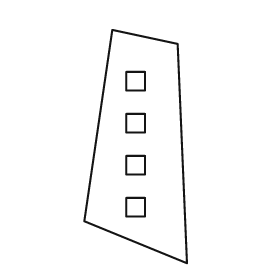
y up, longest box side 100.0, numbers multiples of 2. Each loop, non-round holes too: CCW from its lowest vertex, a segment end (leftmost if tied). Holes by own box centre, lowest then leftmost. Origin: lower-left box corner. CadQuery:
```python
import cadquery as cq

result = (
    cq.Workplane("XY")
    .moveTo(44.0, 0.0)
    .lineTo(40.0, 94.0)
    .lineTo(12.0, 100.0)
    .lineTo(0.0, 18.0)
    .close()
    .moveTo(18.0, 20.0)
    .lineTo(26.0, 20.0)
    .lineTo(26.0, 28.0)
    .lineTo(18.0, 28.0)
    .close()
    .moveTo(18.0, 38.0)
    .lineTo(26.0, 38.0)
    .lineTo(26.0, 46.0)
    .lineTo(18.0, 46.0)
    .close()
    .moveTo(18.0, 56.0)
    .lineTo(26.0, 56.0)
    .lineTo(26.0, 64.0)
    .lineTo(18.0, 64.0)
    .close()
    .moveTo(18.0, 74.0)
    .lineTo(26.0, 74.0)
    .lineTo(26.0, 82.0)
    .lineTo(18.0, 82.0)
    .close()
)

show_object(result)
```